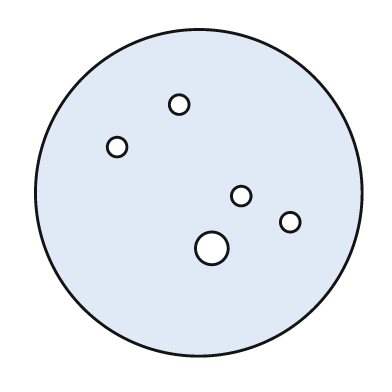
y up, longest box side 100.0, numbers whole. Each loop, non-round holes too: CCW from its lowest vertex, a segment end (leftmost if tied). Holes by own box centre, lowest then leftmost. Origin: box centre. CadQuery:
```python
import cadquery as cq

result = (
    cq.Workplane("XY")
    .moveTo(0.0, 0.0)
    .circle(50.0)
    .moveTo(4.0, -17.0)
    .circle(5.0)
    .moveTo(28.0, -9.0)
    .circle(3.0)
    .moveTo(13.0, -1.0)
    .circle(3.0)
    .moveTo(-25.0, 14.0)
    .circle(3.0)
    .moveTo(-6.0, 27.0)
    .circle(3.0)
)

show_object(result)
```